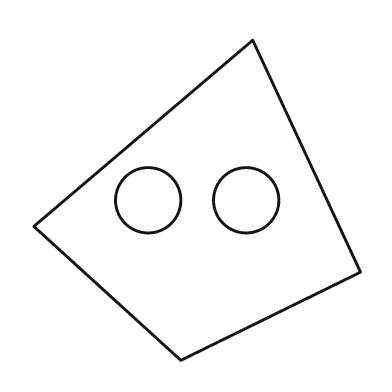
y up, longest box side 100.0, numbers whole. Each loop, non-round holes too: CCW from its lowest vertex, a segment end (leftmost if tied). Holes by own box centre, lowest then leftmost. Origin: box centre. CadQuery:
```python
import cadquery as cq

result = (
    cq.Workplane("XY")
    .moveTo(-5.0, -49.0)
    .lineTo(50.0, -22.0)
    .lineTo(17.0, 49.0)
    .lineTo(-50.0, -8.0)
    .close()
    .moveTo(-15.0, 0.0)
    .circle(10.0)
    .moveTo(15.0, 0.0)
    .circle(10.0)
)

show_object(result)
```